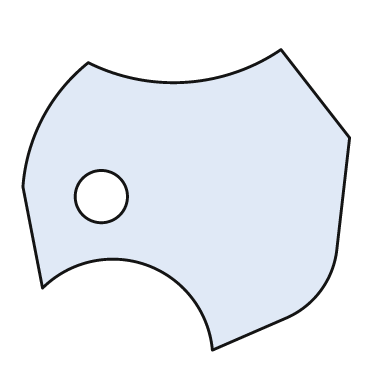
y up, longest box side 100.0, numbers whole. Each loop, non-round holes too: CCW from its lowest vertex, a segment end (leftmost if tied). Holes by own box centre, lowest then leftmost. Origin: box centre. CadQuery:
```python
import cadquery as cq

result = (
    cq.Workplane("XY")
    .moveTo(8.0, -46.0)
    .lineTo(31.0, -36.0)
    .threePointArc((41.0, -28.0), (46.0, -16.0))
    .lineTo(50.0, 19.0)
    .lineTo(29.0, 46.0)
    .threePointArc((0.0, 36.0), (-30.0, 42.0))
    .threePointArc((-44.0, 25.0), (-50.0, 4.0))
    .lineTo(-44.0, -27.0)
    .threePointArc((-12.0, -20.0), (8.0, -46.0))
    .close()
    .moveTo(-26.0, 1.0)
    .circle(8.0)
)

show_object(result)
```